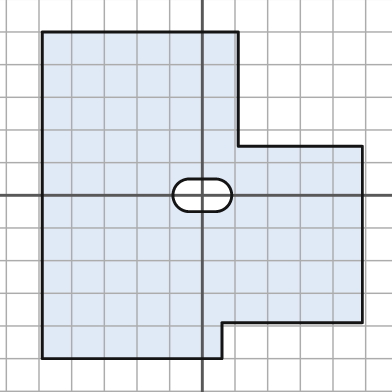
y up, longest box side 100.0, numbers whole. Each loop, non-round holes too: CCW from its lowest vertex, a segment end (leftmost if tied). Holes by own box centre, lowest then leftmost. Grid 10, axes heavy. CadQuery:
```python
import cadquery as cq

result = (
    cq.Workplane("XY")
    .moveTo(-49.0, -50.0)
    .lineTo(6.0, -50.0)
    .lineTo(6.0, -39.0)
    .lineTo(49.0, -39.0)
    .lineTo(49.0, 15.0)
    .lineTo(11.0, 15.0)
    .lineTo(11.0, 50.0)
    .lineTo(-49.0, 50.0)
    .close()
    .moveTo(-4.0, -5.0)
    .lineTo(4.0, -5.0)
    .threePointArc((9.0, 0.0), (4.0, 5.0))
    .lineTo(-4.0, 5.0)
    .threePointArc((-9.0, 0.0), (-4.0, -5.0))
    .close()
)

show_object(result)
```